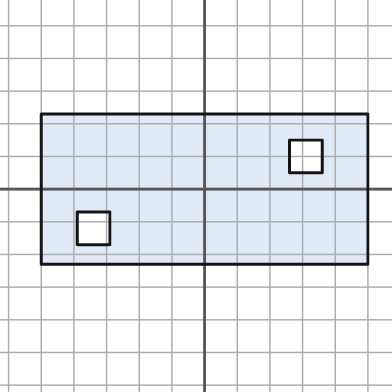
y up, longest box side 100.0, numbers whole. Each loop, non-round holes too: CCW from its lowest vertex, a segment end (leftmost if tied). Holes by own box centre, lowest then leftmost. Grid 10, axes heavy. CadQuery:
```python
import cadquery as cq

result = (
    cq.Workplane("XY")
    .moveTo(-50.0, -23.0)
    .lineTo(50.0, -23.0)
    .lineTo(50.0, 23.0)
    .lineTo(-50.0, 23.0)
    .close()
    .moveTo(-39.0, -17.0)
    .lineTo(-29.0, -17.0)
    .lineTo(-29.0, -7.0)
    .lineTo(-39.0, -7.0)
    .close()
    .moveTo(26.0, 5.0)
    .lineTo(36.0, 5.0)
    .lineTo(36.0, 15.0)
    .lineTo(26.0, 15.0)
    .close()
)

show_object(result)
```